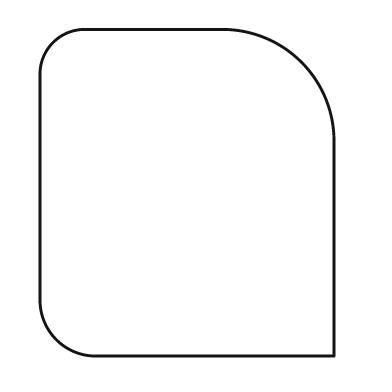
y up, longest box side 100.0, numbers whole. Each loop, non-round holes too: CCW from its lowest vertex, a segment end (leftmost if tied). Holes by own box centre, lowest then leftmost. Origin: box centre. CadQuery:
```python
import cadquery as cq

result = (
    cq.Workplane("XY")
    .moveTo(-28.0, -50.0)
    .lineTo(45.0, -50.0)
    .lineTo(45.0, 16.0)
    .threePointArc((35.0, 40.0), (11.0, 50.0))
    .lineTo(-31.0, 50.0)
    .threePointArc((-41.0, 46.0), (-45.0, 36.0))
    .lineTo(-45.0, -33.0)
    .threePointArc((-40.0, -45.0), (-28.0, -50.0))
    .close()
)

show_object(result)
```